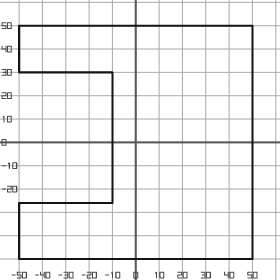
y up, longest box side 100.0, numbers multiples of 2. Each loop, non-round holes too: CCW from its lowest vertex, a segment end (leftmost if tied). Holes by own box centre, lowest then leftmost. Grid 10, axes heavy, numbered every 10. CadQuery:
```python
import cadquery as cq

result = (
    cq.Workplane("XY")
    .moveTo(-50.0, -50.0)
    .lineTo(50.0, -50.0)
    .lineTo(50.0, 50.0)
    .lineTo(-50.0, 50.0)
    .lineTo(-50.0, 30.0)
    .lineTo(-10.0, 30.0)
    .lineTo(-10.0, -26.0)
    .lineTo(-50.0, -26.0)
    .close()
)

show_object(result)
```